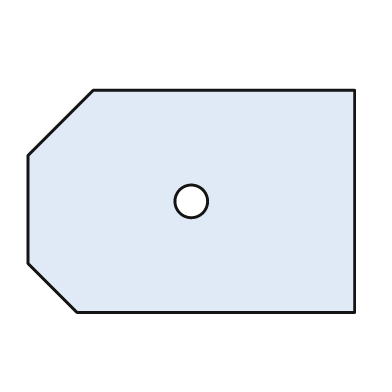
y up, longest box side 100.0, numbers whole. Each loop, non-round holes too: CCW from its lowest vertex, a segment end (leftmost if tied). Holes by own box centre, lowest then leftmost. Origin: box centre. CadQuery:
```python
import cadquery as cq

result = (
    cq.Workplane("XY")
    .moveTo(-35.0, -34.0)
    .lineTo(50.0, -34.0)
    .lineTo(50.0, 34.0)
    .lineTo(-30.0, 34.0)
    .lineTo(-50.0, 14.0)
    .lineTo(-50.0, -19.0)
    .close()
    .moveTo(0.0, 0.0)
    .circle(5.0)
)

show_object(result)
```